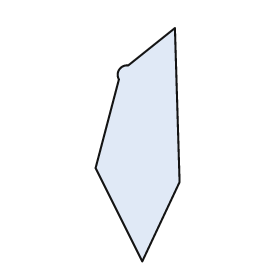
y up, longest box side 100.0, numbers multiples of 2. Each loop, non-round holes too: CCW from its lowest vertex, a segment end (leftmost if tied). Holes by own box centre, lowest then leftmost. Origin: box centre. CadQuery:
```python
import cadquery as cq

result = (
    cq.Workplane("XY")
    .moveTo(2.0, -50.0)
    .lineTo(18.0, -16.0)
    .lineTo(16.0, 50.0)
    .lineTo(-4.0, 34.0)
    .threePointArc((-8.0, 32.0), (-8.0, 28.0))
    .lineTo(-18.0, -10.0)
    .close()
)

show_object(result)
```